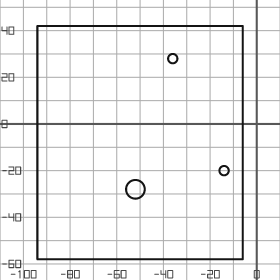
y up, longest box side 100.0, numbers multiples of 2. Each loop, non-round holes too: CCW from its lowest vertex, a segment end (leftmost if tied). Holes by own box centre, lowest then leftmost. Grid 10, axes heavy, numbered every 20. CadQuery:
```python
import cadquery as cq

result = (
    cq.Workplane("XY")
    .moveTo(-94.0, -58.0)
    .lineTo(-6.0, -58.0)
    .lineTo(-6.0, 42.0)
    .lineTo(-94.0, 42.0)
    .close()
    .moveTo(-52.0, -28.0)
    .circle(4.0)
    .moveTo(-14.0, -20.0)
    .circle(2.0)
    .moveTo(-36.0, 28.0)
    .circle(2.0)
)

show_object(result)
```